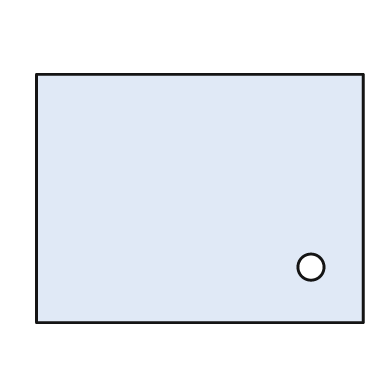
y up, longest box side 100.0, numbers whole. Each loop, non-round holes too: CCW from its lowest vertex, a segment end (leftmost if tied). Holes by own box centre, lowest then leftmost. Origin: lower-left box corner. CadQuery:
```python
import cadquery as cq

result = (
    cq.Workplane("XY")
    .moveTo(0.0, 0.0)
    .lineTo(100.0, 0.0)
    .lineTo(100.0, 76.0)
    .lineTo(0.0, 76.0)
    .close()
    .moveTo(84.0, 17.0)
    .circle(4.0)
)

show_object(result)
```